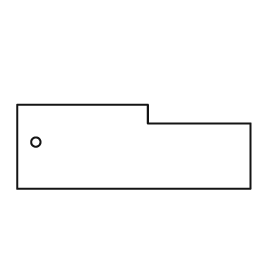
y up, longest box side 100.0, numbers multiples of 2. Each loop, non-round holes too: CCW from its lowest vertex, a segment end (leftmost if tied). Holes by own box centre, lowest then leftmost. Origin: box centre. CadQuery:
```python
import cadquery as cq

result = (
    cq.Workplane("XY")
    .moveTo(-50.0, -18.0)
    .lineTo(50.0, -18.0)
    .lineTo(50.0, 10.0)
    .lineTo(6.0, 10.0)
    .lineTo(6.0, 18.0)
    .lineTo(-50.0, 18.0)
    .close()
    .moveTo(-42.0, 2.0)
    .circle(2.0)
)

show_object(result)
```